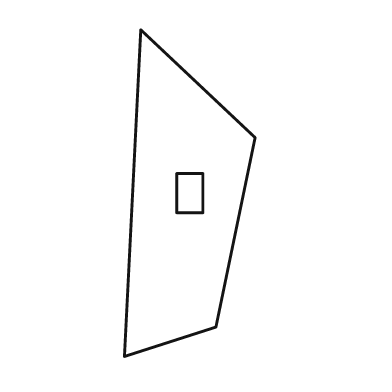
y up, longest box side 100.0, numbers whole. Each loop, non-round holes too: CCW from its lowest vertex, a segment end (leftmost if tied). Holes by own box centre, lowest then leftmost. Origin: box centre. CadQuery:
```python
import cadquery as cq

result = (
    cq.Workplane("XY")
    .moveTo(-20.0, -50.0)
    .lineTo(8.0, -41.0)
    .lineTo(20.0, 17.0)
    .lineTo(-15.0, 50.0)
    .close()
    .moveTo(-4.0, -6.0)
    .lineTo(4.0, -6.0)
    .lineTo(4.0, 6.0)
    .lineTo(-4.0, 6.0)
    .close()
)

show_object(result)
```